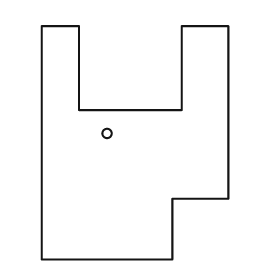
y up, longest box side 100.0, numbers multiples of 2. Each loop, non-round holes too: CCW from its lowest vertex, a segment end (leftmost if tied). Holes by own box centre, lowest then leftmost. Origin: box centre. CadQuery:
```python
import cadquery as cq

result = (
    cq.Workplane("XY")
    .moveTo(-40.0, -50.0)
    .lineTo(16.0, -50.0)
    .lineTo(16.0, -24.0)
    .lineTo(40.0, -24.0)
    .lineTo(40.0, 50.0)
    .lineTo(20.0, 50.0)
    .lineTo(20.0, 14.0)
    .lineTo(-24.0, 14.0)
    .lineTo(-24.0, 50.0)
    .lineTo(-40.0, 50.0)
    .close()
    .moveTo(-12.0, 4.0)
    .circle(2.0)
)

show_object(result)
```